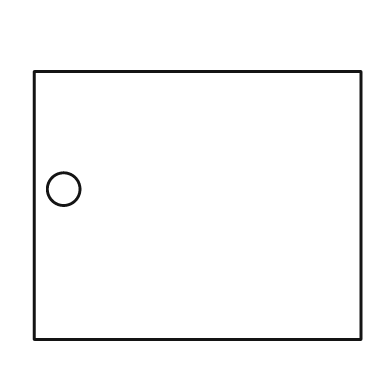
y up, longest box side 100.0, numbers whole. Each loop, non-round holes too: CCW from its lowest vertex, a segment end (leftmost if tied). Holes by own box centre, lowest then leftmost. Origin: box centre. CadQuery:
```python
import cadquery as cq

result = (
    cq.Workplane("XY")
    .moveTo(-50.0, -41.0)
    .lineTo(50.0, -41.0)
    .lineTo(50.0, 41.0)
    .lineTo(-50.0, 41.0)
    .close()
    .moveTo(-41.0, 5.0)
    .circle(5.0)
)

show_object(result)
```